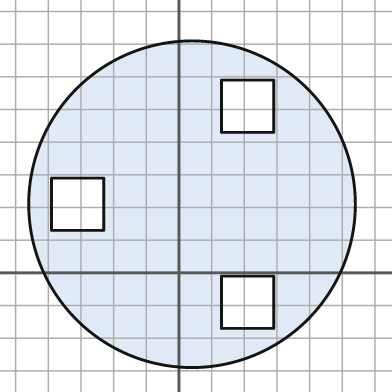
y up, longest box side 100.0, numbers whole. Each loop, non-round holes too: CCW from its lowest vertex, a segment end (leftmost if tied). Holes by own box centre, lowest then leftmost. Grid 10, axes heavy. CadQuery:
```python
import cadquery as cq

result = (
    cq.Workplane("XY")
    .moveTo(4.0, 21.0)
    .circle(50.0)
    .moveTo(13.0, -17.0)
    .lineTo(29.0, -17.0)
    .lineTo(29.0, -1.0)
    .lineTo(13.0, -1.0)
    .close()
    .moveTo(-39.0, 13.0)
    .lineTo(-23.0, 13.0)
    .lineTo(-23.0, 29.0)
    .lineTo(-39.0, 29.0)
    .close()
    .moveTo(13.0, 43.0)
    .lineTo(29.0, 43.0)
    .lineTo(29.0, 59.0)
    .lineTo(13.0, 59.0)
    .close()
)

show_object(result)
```